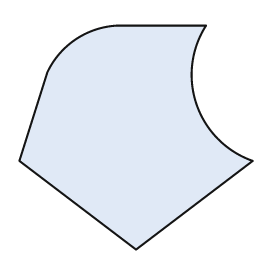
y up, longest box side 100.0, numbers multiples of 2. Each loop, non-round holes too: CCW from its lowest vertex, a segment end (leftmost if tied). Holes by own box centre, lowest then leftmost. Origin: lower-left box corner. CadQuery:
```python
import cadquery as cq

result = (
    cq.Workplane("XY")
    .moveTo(50.0, 0.0)
    .lineTo(100.0, 38.0)
    .threePointArc((76.0, 62.0), (80.0, 96.0))
    .lineTo(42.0, 96.0)
    .threePointArc((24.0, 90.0), (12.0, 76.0))
    .lineTo(0.0, 38.0)
    .close()
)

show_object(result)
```